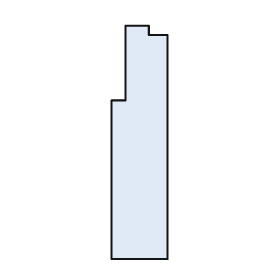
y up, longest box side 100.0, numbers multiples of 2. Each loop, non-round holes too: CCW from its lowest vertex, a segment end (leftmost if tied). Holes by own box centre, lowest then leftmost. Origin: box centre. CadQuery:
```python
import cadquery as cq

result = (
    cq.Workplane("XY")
    .moveTo(-12.0, -50.0)
    .lineTo(12.0, -50.0)
    .lineTo(12.0, 46.0)
    .lineTo(4.0, 46.0)
    .lineTo(4.0, 50.0)
    .lineTo(-6.0, 50.0)
    .lineTo(-6.0, 18.0)
    .lineTo(-12.0, 18.0)
    .close()
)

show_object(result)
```